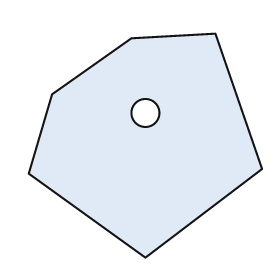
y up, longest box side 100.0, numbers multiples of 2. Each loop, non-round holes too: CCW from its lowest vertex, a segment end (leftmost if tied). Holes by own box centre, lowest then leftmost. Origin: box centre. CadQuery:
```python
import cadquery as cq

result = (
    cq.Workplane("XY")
    .moveTo(0.0, -48.0)
    .lineTo(50.0, -10.0)
    .lineTo(30.0, 48.0)
    .lineTo(-6.0, 46.0)
    .lineTo(-40.0, 22.0)
    .lineTo(-50.0, -12.0)
    .close()
    .moveTo(0.0, 14.0)
    .circle(6.0)
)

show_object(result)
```